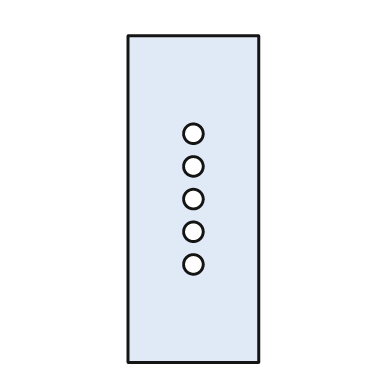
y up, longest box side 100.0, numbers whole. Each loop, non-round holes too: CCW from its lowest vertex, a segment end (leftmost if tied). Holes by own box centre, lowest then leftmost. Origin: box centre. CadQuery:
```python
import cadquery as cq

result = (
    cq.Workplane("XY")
    .moveTo(-20.0, -50.0)
    .lineTo(20.0, -50.0)
    .lineTo(20.0, 50.0)
    .lineTo(-20.0, 50.0)
    .close()
    .moveTo(0.0, -20.0)
    .circle(3.0)
    .moveTo(0.0, -10.0)
    .circle(3.0)
    .moveTo(0.0, 0.0)
    .circle(3.0)
    .moveTo(0.0, 10.0)
    .circle(3.0)
    .moveTo(0.0, 20.0)
    .circle(3.0)
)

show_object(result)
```